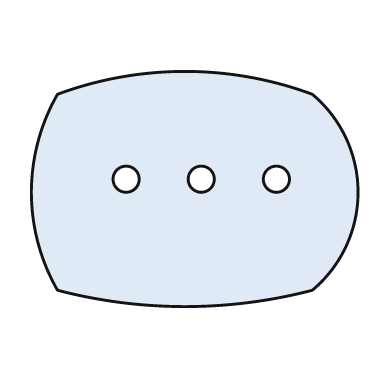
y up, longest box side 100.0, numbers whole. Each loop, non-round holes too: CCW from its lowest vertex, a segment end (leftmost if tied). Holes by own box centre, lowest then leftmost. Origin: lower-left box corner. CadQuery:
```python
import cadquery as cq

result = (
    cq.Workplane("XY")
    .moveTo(8.0, 5.0)
    .threePointArc((47.0, 0.0), (86.0, 5.0))
    .threePointArc((100.0, 35.0), (86.0, 65.0))
    .threePointArc((47.0, 72.0), (8.0, 65.0))
    .threePointArc((0.0, 35.0), (8.0, 5.0))
    .close()
    .moveTo(29.0, 39.0)
    .circle(4.0)
    .moveTo(52.0, 39.0)
    .circle(4.0)
    .moveTo(75.0, 39.0)
    .circle(4.0)
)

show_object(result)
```